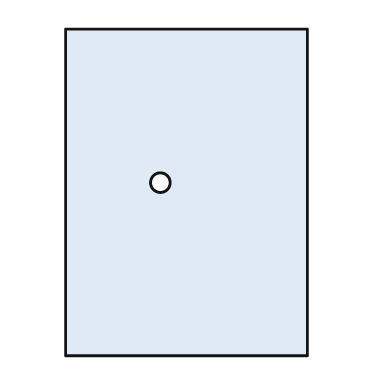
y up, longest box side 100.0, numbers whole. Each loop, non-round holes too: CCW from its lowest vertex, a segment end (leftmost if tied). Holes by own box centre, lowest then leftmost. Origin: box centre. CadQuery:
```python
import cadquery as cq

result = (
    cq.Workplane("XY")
    .moveTo(-37.0, -50.0)
    .lineTo(37.0, -50.0)
    .lineTo(37.0, 50.0)
    .lineTo(-37.0, 50.0)
    .close()
    .moveTo(-8.0, 3.0)
    .circle(3.0)
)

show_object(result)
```